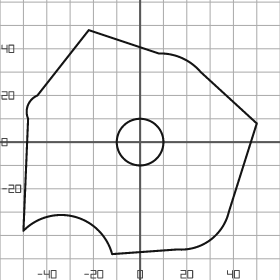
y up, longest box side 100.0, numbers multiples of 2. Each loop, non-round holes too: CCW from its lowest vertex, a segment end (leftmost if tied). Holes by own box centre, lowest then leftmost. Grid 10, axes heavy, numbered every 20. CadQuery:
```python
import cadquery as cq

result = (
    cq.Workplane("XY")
    .moveTo(-12.0, -48.0)
    .lineTo(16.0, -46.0)
    .threePointArc((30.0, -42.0), (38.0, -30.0))
    .lineTo(50.0, 8.0)
    .lineTo(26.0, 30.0)
    .threePointArc((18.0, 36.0), (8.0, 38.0))
    .lineTo(-22.0, 48.0)
    .lineTo(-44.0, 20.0)
    .threePointArc((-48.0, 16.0), (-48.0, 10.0))
    .lineTo(-50.0, -38.0)
    .threePointArc((-28.0, -32.0), (-12.0, -48.0))
    .close()
    .moveTo(0.0, 0.0)
    .circle(10.0)
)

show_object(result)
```